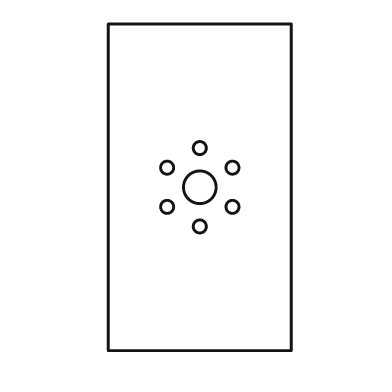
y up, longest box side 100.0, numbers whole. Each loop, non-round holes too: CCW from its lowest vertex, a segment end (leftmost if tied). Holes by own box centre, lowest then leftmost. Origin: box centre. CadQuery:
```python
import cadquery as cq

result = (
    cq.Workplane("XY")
    .moveTo(-28.0, -50.0)
    .lineTo(28.0, -50.0)
    .lineTo(28.0, 50.0)
    .lineTo(-28.0, 50.0)
    .close()
    .moveTo(0.0, -12.0)
    .circle(2.0)
    .moveTo(-10.0, -6.0)
    .circle(2.0)
    .moveTo(10.0, -6.0)
    .circle(2.0)
    .moveTo(0.0, 0.0)
    .circle(5.0)
    .moveTo(-10.0, 6.0)
    .circle(2.0)
    .moveTo(10.0, 6.0)
    .circle(2.0)
    .moveTo(0.0, 12.0)
    .circle(2.0)
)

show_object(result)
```